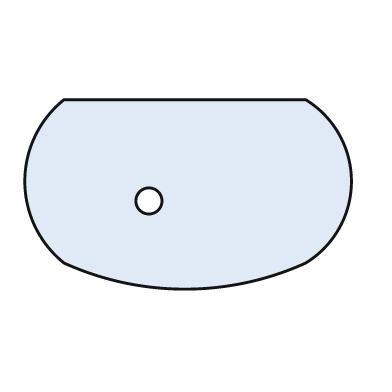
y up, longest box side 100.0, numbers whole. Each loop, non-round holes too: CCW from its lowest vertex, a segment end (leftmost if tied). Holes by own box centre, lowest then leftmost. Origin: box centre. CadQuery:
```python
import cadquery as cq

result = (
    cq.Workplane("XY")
    .moveTo(-38.0, -21.0)
    .threePointArc((-1.0, -29.0), (36.0, -21.0))
    .threePointArc((50.0, 4.0), (36.0, 29.0))
    .lineTo(-38.0, 29.0)
    .threePointArc((-50.0, 4.0), (-38.0, -21.0))
    .close()
    .moveTo(-12.0, -2.0)
    .circle(4.0)
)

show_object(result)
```